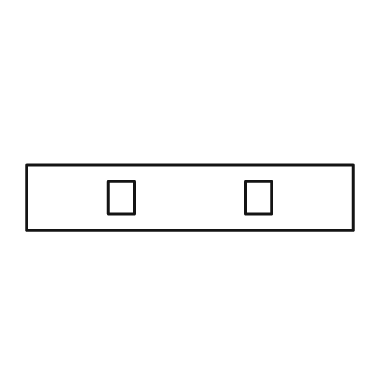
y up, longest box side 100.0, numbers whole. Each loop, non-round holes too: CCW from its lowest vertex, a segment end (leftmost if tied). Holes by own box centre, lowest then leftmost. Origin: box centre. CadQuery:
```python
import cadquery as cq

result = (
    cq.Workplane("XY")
    .moveTo(-50.0, -10.0)
    .lineTo(50.0, -10.0)
    .lineTo(50.0, 10.0)
    .lineTo(-50.0, 10.0)
    .close()
    .moveTo(-25.0, -5.0)
    .lineTo(-17.0, -5.0)
    .lineTo(-17.0, 5.0)
    .lineTo(-25.0, 5.0)
    .close()
    .moveTo(17.0, -5.0)
    .lineTo(25.0, -5.0)
    .lineTo(25.0, 5.0)
    .lineTo(17.0, 5.0)
    .close()
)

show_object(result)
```